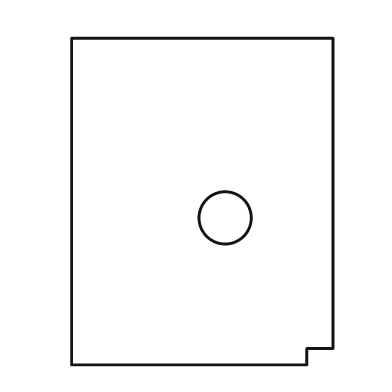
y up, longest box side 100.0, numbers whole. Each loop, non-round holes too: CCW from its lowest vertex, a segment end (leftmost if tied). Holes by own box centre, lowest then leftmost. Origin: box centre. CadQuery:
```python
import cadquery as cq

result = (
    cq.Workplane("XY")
    .moveTo(-40.0, -50.0)
    .lineTo(32.0, -50.0)
    .lineTo(32.0, -45.0)
    .lineTo(40.0, -45.0)
    .lineTo(40.0, 50.0)
    .lineTo(-40.0, 50.0)
    .close()
    .moveTo(7.0, -5.0)
    .circle(8.0)
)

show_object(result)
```